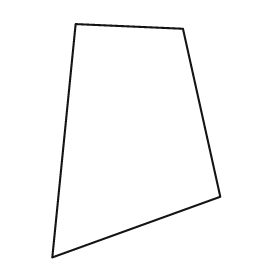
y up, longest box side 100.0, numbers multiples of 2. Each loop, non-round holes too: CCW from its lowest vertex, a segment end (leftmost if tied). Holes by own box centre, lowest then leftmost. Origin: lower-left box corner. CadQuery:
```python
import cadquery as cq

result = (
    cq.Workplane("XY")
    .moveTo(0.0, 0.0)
    .lineTo(72.0, 26.0)
    .lineTo(56.0, 98.0)
    .lineTo(10.0, 100.0)
    .close()
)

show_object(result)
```